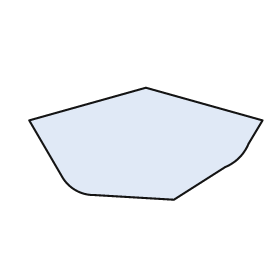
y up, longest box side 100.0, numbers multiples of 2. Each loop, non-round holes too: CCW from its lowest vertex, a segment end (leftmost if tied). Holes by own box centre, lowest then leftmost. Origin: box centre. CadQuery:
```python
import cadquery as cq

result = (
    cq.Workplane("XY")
    .moveTo(12.0, -24.0)
    .lineTo(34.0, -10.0)
    .threePointArc((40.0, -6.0), (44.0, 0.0))
    .lineTo(50.0, 10.0)
    .lineTo(0.0, 24.0)
    .lineTo(-50.0, 10.0)
    .lineTo(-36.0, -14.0)
    .threePointArc((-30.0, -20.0), (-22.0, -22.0))
    .close()
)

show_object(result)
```